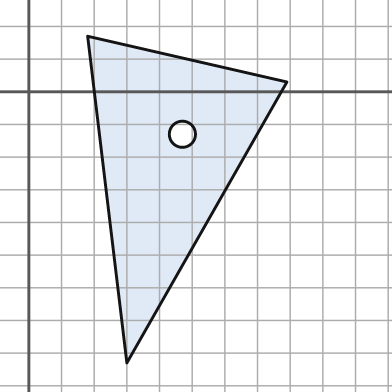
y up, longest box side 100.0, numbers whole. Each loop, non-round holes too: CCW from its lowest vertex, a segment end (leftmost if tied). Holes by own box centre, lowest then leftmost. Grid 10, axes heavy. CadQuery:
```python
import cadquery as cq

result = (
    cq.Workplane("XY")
    .moveTo(30.0, -83.0)
    .lineTo(79.0, 3.0)
    .lineTo(18.0, 17.0)
    .close()
    .moveTo(47.0, -13.0)
    .circle(4.0)
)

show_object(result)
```